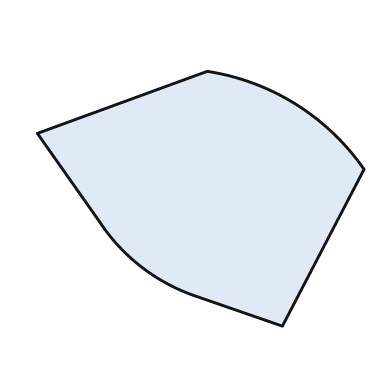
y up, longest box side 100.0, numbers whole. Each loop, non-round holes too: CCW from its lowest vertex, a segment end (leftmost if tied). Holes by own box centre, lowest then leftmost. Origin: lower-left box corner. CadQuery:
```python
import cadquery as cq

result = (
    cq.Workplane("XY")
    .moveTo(75.0, 0.0)
    .lineTo(100.0, 48.0)
    .threePointArc((79.0, 68.0), (52.0, 78.0))
    .lineTo(0.0, 59.0)
    .lineTo(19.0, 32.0)
    .threePointArc((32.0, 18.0), (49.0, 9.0))
    .close()
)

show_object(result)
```